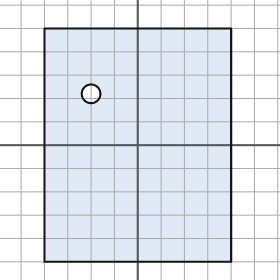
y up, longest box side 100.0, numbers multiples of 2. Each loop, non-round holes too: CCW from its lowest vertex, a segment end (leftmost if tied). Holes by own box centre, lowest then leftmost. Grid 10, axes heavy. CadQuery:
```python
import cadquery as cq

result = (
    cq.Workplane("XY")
    .moveTo(-40.0, -50.0)
    .lineTo(40.0, -50.0)
    .lineTo(40.0, 50.0)
    .lineTo(-40.0, 50.0)
    .close()
    .moveTo(-20.0, 22.0)
    .circle(4.0)
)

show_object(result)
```